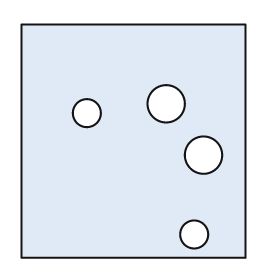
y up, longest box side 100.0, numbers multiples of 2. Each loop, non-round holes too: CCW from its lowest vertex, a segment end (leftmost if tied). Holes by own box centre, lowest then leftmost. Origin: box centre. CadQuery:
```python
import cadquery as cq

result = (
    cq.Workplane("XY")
    .moveTo(-48.0, -50.0)
    .lineTo(48.0, -50.0)
    .lineTo(48.0, 50.0)
    .lineTo(-48.0, 50.0)
    .close()
    .moveTo(26.0, -40.0)
    .circle(6.0)
    .moveTo(30.0, -6.0)
    .circle(8.0)
    .moveTo(-20.0, 12.0)
    .circle(6.0)
    .moveTo(14.0, 16.0)
    .circle(8.0)
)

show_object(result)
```